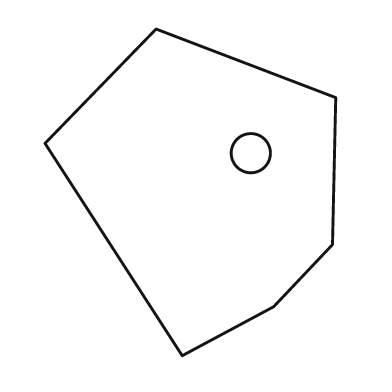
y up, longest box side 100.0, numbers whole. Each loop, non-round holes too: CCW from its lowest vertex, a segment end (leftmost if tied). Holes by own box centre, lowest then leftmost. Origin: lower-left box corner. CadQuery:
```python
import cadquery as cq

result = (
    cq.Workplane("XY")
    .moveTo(42.0, 0.0)
    .lineTo(70.0, 15.0)
    .lineTo(88.0, 34.0)
    .lineTo(89.0, 79.0)
    .lineTo(34.0, 100.0)
    .lineTo(0.0, 65.0)
    .close()
    .moveTo(63.0, 62.0)
    .circle(6.0)
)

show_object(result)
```